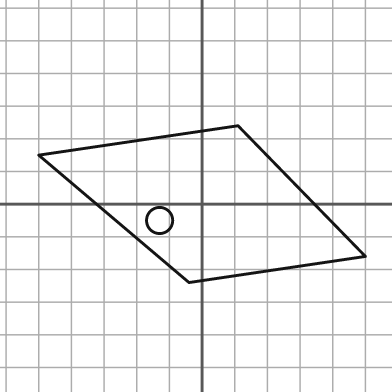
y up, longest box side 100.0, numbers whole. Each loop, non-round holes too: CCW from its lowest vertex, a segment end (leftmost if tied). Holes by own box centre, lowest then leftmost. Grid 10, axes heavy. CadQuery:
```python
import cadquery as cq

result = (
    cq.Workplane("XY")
    .moveTo(-4.0, -24.0)
    .lineTo(50.0, -16.0)
    .lineTo(11.0, 24.0)
    .lineTo(-50.0, 15.0)
    .close()
    .moveTo(-13.0, -5.0)
    .circle(4.0)
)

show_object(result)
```